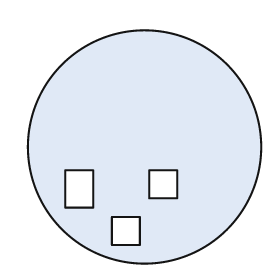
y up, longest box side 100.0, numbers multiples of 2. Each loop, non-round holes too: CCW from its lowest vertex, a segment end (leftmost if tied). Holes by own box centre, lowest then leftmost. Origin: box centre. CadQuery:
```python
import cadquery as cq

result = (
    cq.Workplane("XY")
    .moveTo(0.0, 0.0)
    .circle(50.0)
    .moveTo(-14.0, -42.0)
    .lineTo(-2.0, -42.0)
    .lineTo(-2.0, -30.0)
    .lineTo(-14.0, -30.0)
    .close()
    .moveTo(-34.0, -26.0)
    .lineTo(-22.0, -26.0)
    .lineTo(-22.0, -10.0)
    .lineTo(-34.0, -10.0)
    .close()
    .moveTo(2.0, -22.0)
    .lineTo(14.0, -22.0)
    .lineTo(14.0, -10.0)
    .lineTo(2.0, -10.0)
    .close()
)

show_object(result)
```